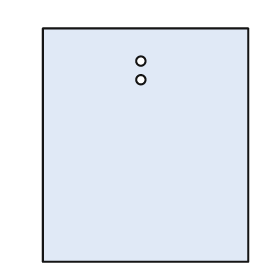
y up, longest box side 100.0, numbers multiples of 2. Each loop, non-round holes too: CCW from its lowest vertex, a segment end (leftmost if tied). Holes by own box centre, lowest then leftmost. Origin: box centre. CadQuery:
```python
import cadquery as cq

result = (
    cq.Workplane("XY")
    .moveTo(-44.0, -50.0)
    .lineTo(44.0, -50.0)
    .lineTo(44.0, 50.0)
    .lineTo(-44.0, 50.0)
    .close()
    .moveTo(-2.0, 28.0)
    .circle(2.0)
    .moveTo(-2.0, 36.0)
    .circle(2.0)
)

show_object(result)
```